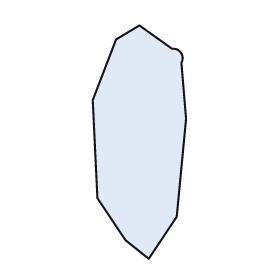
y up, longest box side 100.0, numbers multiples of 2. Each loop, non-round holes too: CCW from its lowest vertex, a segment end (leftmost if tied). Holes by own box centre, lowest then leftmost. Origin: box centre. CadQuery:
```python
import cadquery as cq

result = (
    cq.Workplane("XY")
    .moveTo(4.0, -50.0)
    .lineTo(16.0, -32.0)
    .lineTo(20.0, 10.0)
    .lineTo(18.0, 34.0)
    .threePointArc((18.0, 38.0), (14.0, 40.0))
    .lineTo(0.0, 50.0)
    .lineTo(-10.0, 44.0)
    .lineTo(-20.0, 18.0)
    .lineTo(-18.0, -24.0)
    .lineTo(-6.0, -42.0)
    .close()
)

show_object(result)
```